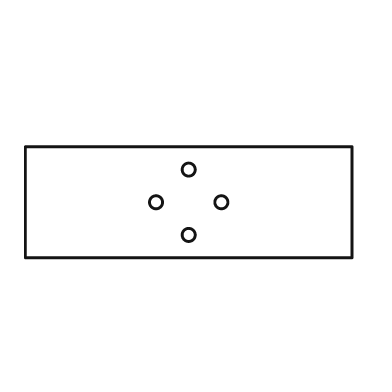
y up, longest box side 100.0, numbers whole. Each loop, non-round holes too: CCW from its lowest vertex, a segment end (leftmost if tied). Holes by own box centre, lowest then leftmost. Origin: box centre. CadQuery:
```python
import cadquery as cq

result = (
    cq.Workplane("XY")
    .moveTo(-50.0, -17.0)
    .lineTo(50.0, -17.0)
    .lineTo(50.0, 17.0)
    .lineTo(-50.0, 17.0)
    .close()
    .moveTo(0.0, -10.0)
    .circle(2.0)
    .moveTo(-10.0, 0.0)
    .circle(2.0)
    .moveTo(10.0, 0.0)
    .circle(2.0)
    .moveTo(0.0, 10.0)
    .circle(2.0)
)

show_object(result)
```